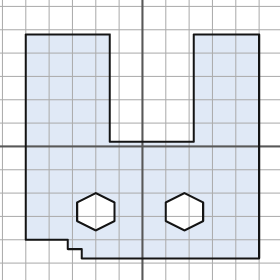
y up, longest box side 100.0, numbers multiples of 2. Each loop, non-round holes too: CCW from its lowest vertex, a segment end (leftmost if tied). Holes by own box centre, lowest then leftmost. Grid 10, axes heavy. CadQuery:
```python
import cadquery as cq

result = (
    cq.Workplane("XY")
    .moveTo(-26.0, -48.0)
    .lineTo(50.0, -48.0)
    .lineTo(50.0, 48.0)
    .lineTo(22.0, 48.0)
    .lineTo(22.0, 2.0)
    .lineTo(-14.0, 2.0)
    .lineTo(-14.0, 48.0)
    .lineTo(-50.0, 48.0)
    .lineTo(-50.0, -40.0)
    .lineTo(-32.0, -40.0)
    .lineTo(-32.0, -44.0)
    .lineTo(-26.0, -44.0)
    .close()
    .moveTo(-20.0, -36.0)
    .lineTo(-12.0, -32.0)
    .lineTo(-12.0, -24.0)
    .lineTo(-20.0, -20.0)
    .lineTo(-28.0, -24.0)
    .lineTo(-28.0, -32.0)
    .close()
    .moveTo(18.0, -36.0)
    .lineTo(26.0, -32.0)
    .lineTo(26.0, -24.0)
    .lineTo(18.0, -20.0)
    .lineTo(10.0, -24.0)
    .lineTo(10.0, -32.0)
    .close()
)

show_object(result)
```